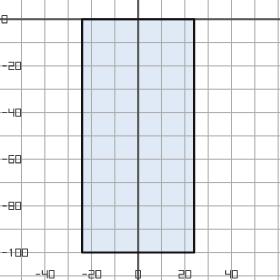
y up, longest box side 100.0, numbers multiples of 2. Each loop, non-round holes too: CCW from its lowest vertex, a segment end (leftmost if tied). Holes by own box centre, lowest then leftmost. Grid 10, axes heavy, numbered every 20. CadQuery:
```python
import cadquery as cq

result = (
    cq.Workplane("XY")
    .moveTo(-24.0, -100.0)
    .lineTo(24.0, -100.0)
    .lineTo(24.0, 0.0)
    .lineTo(-24.0, 0.0)
    .close()
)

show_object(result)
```